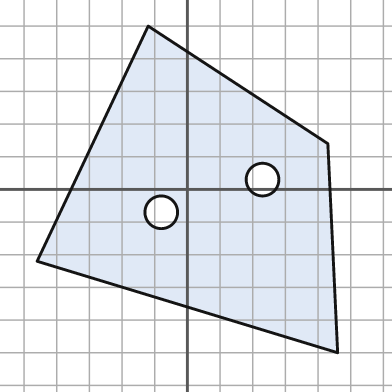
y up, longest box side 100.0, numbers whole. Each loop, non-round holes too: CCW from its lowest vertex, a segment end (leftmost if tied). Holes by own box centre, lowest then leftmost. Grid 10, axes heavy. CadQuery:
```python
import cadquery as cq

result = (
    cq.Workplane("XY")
    .moveTo(46.0, -50.0)
    .lineTo(43.0, 14.0)
    .lineTo(-12.0, 50.0)
    .lineTo(-46.0, -22.0)
    .close()
    .moveTo(-8.0, -7.0)
    .circle(5.0)
    .moveTo(23.0, 3.0)
    .circle(5.0)
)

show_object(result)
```